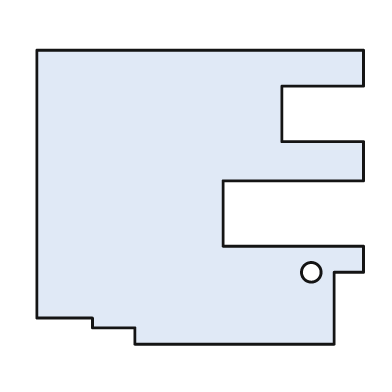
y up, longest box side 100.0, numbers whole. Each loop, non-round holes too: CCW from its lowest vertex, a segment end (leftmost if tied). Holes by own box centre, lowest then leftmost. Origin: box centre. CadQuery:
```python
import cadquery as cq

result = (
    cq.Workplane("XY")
    .moveTo(-20.0, -45.0)
    .lineTo(41.0, -45.0)
    .lineTo(41.0, -23.0)
    .lineTo(50.0, -23.0)
    .lineTo(50.0, -15.0)
    .lineTo(7.0, -15.0)
    .lineTo(7.0, 5.0)
    .lineTo(50.0, 5.0)
    .lineTo(50.0, 17.0)
    .lineTo(25.0, 17.0)
    .lineTo(25.0, 34.0)
    .lineTo(50.0, 34.0)
    .lineTo(50.0, 45.0)
    .lineTo(-50.0, 45.0)
    .lineTo(-50.0, -37.0)
    .lineTo(-33.0, -37.0)
    .lineTo(-33.0, -40.0)
    .lineTo(-20.0, -40.0)
    .close()
    .moveTo(34.0, -23.0)
    .circle(3.0)
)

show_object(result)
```